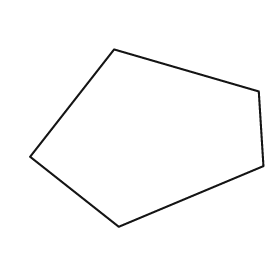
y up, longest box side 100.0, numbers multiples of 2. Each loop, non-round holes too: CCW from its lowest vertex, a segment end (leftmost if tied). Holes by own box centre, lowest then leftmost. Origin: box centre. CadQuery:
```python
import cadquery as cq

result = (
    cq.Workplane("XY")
    .moveTo(-12.0, -38.0)
    .lineTo(50.0, -12.0)
    .lineTo(48.0, 20.0)
    .lineTo(-14.0, 38.0)
    .lineTo(-50.0, -8.0)
    .close()
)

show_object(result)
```